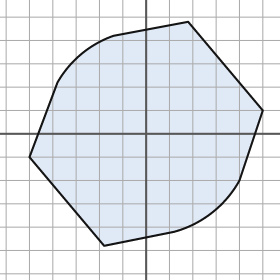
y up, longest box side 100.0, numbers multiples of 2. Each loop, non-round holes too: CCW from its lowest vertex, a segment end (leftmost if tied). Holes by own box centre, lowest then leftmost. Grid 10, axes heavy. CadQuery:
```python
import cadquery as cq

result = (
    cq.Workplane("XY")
    .moveTo(-18.0, -48.0)
    .lineTo(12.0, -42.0)
    .threePointArc((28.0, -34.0), (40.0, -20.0))
    .lineTo(50.0, 10.0)
    .lineTo(18.0, 48.0)
    .lineTo(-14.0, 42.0)
    .threePointArc((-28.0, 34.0), (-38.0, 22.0))
    .lineTo(-50.0, -10.0)
    .close()
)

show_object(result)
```